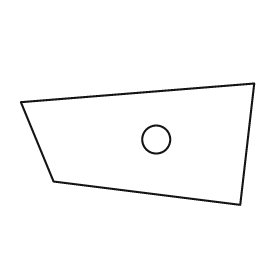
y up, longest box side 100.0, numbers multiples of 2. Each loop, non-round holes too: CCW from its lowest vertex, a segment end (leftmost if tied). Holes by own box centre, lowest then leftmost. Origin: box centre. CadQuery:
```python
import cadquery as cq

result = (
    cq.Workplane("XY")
    .moveTo(44.0, -26.0)
    .lineTo(50.0, 26.0)
    .lineTo(-50.0, 18.0)
    .lineTo(-36.0, -16.0)
    .close()
    .moveTo(8.0, 2.0)
    .circle(6.0)
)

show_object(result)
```